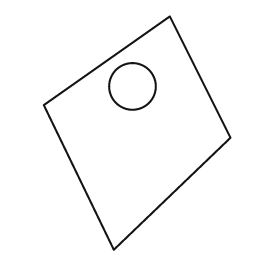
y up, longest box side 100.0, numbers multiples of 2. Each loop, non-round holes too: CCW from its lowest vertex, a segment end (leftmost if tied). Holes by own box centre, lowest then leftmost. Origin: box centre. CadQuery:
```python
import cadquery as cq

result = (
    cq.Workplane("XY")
    .moveTo(-10.0, -50.0)
    .lineTo(40.0, -2.0)
    .lineTo(14.0, 50.0)
    .lineTo(-40.0, 12.0)
    .close()
    .moveTo(-2.0, 20.0)
    .circle(10.0)
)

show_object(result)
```